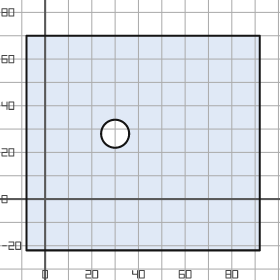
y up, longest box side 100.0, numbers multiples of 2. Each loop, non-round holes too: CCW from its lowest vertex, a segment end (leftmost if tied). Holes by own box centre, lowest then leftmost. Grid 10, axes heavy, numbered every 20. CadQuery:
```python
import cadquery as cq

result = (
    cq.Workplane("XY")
    .moveTo(-8.0, -22.0)
    .lineTo(92.0, -22.0)
    .lineTo(92.0, 70.0)
    .lineTo(-8.0, 70.0)
    .close()
    .moveTo(30.0, 28.0)
    .circle(6.0)
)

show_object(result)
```